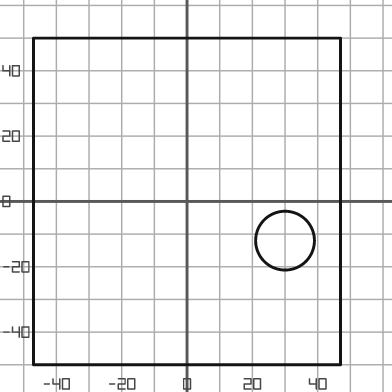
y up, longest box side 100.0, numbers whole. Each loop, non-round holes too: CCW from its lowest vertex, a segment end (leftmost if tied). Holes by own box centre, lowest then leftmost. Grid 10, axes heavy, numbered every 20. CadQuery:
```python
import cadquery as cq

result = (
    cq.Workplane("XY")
    .moveTo(-47.0, -50.0)
    .lineTo(47.0, -50.0)
    .lineTo(47.0, 50.0)
    .lineTo(-47.0, 50.0)
    .close()
    .moveTo(30.0, -12.0)
    .circle(9.0)
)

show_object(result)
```